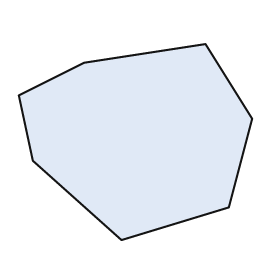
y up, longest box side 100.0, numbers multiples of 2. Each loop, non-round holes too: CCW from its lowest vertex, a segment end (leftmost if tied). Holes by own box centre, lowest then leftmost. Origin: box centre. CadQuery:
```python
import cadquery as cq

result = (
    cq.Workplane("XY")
    .moveTo(-6.0, -42.0)
    .lineTo(40.0, -28.0)
    .lineTo(50.0, 10.0)
    .lineTo(30.0, 42.0)
    .lineTo(-22.0, 34.0)
    .lineTo(-50.0, 20.0)
    .lineTo(-44.0, -8.0)
    .close()
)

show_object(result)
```